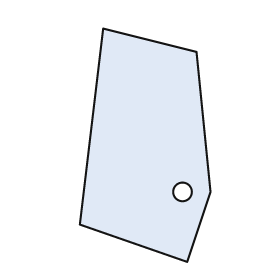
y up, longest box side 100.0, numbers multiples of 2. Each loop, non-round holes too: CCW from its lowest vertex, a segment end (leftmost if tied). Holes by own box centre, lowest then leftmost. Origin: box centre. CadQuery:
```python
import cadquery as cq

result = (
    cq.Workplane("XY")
    .moveTo(18.0, -50.0)
    .lineTo(28.0, -20.0)
    .lineTo(22.0, 40.0)
    .lineTo(-18.0, 50.0)
    .lineTo(-28.0, -34.0)
    .close()
    .moveTo(16.0, -20.0)
    .circle(4.0)
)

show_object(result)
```